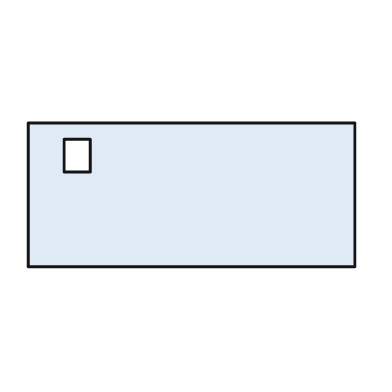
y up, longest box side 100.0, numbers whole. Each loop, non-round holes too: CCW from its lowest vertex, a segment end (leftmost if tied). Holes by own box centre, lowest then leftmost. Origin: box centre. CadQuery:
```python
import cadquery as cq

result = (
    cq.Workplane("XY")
    .moveTo(-50.0, -22.0)
    .lineTo(50.0, -22.0)
    .lineTo(50.0, 22.0)
    .lineTo(-50.0, 22.0)
    .close()
    .moveTo(-39.0, 7.0)
    .lineTo(-31.0, 7.0)
    .lineTo(-31.0, 17.0)
    .lineTo(-39.0, 17.0)
    .close()
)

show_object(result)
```